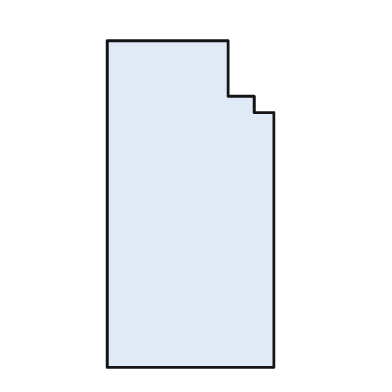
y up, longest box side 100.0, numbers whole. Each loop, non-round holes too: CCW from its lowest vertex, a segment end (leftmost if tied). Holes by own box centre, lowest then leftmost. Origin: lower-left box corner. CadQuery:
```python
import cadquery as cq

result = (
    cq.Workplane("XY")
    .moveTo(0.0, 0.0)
    .lineTo(51.0, 0.0)
    .lineTo(51.0, 78.0)
    .lineTo(45.0, 78.0)
    .lineTo(45.0, 83.0)
    .lineTo(37.0, 83.0)
    .lineTo(37.0, 100.0)
    .lineTo(0.0, 100.0)
    .close()
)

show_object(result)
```